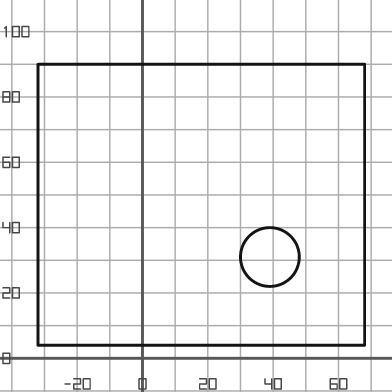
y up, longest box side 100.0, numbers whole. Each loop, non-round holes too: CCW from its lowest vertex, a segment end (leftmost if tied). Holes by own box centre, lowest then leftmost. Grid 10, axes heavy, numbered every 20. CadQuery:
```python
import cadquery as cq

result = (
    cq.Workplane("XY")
    .moveTo(-32.0, 4.0)
    .lineTo(68.0, 4.0)
    .lineTo(68.0, 90.0)
    .lineTo(-32.0, 90.0)
    .close()
    .moveTo(39.0, 31.0)
    .circle(9.0)
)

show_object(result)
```